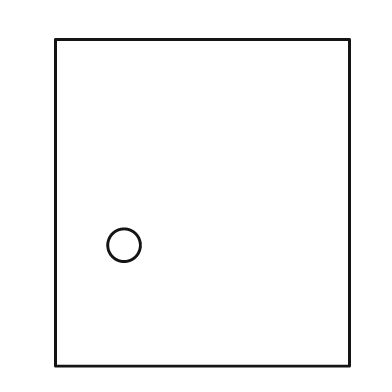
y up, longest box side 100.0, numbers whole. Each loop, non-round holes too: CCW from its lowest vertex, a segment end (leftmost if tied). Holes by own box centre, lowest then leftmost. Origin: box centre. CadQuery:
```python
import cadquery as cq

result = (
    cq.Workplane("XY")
    .moveTo(-45.0, -50.0)
    .lineTo(45.0, -50.0)
    .lineTo(45.0, 50.0)
    .lineTo(-45.0, 50.0)
    .close()
    .moveTo(-24.0, -13.0)
    .circle(5.0)
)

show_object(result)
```